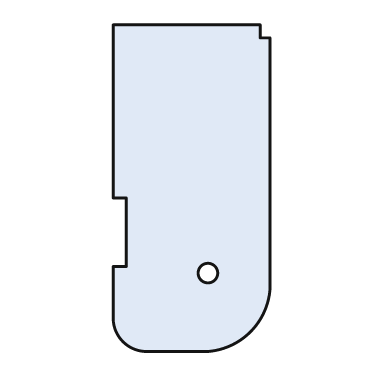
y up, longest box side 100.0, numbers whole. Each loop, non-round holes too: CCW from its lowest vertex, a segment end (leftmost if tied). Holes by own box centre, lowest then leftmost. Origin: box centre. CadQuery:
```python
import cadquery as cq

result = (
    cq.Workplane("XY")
    .moveTo(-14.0, -50.0)
    .lineTo(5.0, -50.0)
    .threePointArc((18.0, -44.0), (24.0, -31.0))
    .lineTo(24.0, 46.0)
    .lineTo(21.0, 46.0)
    .lineTo(21.0, 50.0)
    .lineTo(-24.0, 50.0)
    .lineTo(-24.0, -3.0)
    .lineTo(-20.0, -3.0)
    .lineTo(-20.0, -24.0)
    .lineTo(-24.0, -24.0)
    .lineTo(-24.0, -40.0)
    .threePointArc((-21.0, -47.0), (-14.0, -50.0))
    .close()
    .moveTo(5.0, -26.0)
    .circle(3.0)
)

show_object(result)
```